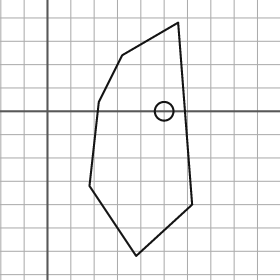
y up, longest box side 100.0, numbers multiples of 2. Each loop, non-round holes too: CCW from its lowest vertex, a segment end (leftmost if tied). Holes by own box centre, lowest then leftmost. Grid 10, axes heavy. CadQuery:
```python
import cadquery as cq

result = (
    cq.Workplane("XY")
    .moveTo(38.0, -62.0)
    .lineTo(62.0, -40.0)
    .lineTo(56.0, 38.0)
    .lineTo(32.0, 24.0)
    .lineTo(22.0, 4.0)
    .lineTo(18.0, -32.0)
    .close()
    .moveTo(50.0, 0.0)
    .circle(4.0)
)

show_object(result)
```